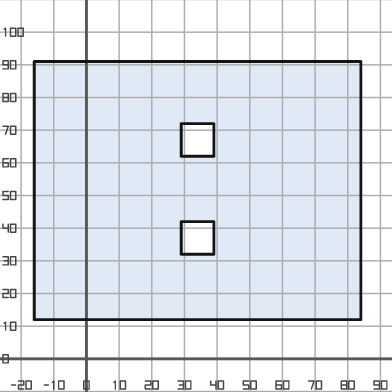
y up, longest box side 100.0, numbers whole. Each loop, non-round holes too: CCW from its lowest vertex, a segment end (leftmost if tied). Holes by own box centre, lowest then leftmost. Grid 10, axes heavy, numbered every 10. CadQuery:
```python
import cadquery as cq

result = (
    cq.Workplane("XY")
    .moveTo(-16.0, 12.0)
    .lineTo(84.0, 12.0)
    .lineTo(84.0, 91.0)
    .lineTo(-16.0, 91.0)
    .close()
    .moveTo(29.0, 32.0)
    .lineTo(39.0, 32.0)
    .lineTo(39.0, 42.0)
    .lineTo(29.0, 42.0)
    .close()
    .moveTo(29.0, 62.0)
    .lineTo(39.0, 62.0)
    .lineTo(39.0, 72.0)
    .lineTo(29.0, 72.0)
    .close()
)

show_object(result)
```